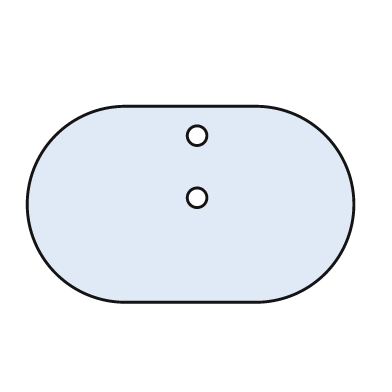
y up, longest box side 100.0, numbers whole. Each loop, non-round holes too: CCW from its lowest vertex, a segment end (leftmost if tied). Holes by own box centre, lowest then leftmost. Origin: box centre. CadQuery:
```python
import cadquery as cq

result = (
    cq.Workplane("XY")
    .moveTo(-20.0, -30.0)
    .lineTo(20.0, -30.0)
    .threePointArc((50.0, 0.0), (20.0, 30.0))
    .lineTo(-20.0, 30.0)
    .threePointArc((-50.0, 0.0), (-20.0, -30.0))
    .close()
    .moveTo(2.0, 2.0)
    .circle(3.0)
    .moveTo(2.0, 21.0)
    .circle(3.0)
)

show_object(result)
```